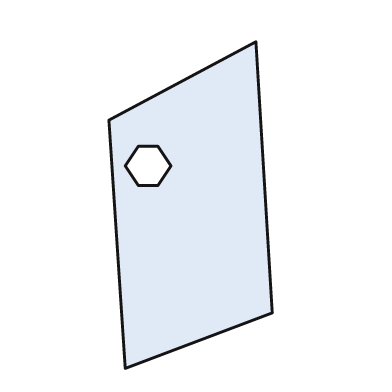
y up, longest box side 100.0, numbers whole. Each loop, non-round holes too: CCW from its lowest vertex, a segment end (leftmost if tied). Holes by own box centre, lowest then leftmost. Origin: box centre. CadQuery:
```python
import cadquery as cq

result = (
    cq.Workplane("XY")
    .moveTo(-20.0, -50.0)
    .lineTo(25.0, -33.0)
    .lineTo(20.0, 50.0)
    .lineTo(-25.0, 26.0)
    .close()
    .moveTo(-16.0, 6.0)
    .lineTo(-10.0, 6.0)
    .lineTo(-6.0, 12.0)
    .lineTo(-10.0, 18.0)
    .lineTo(-16.0, 18.0)
    .lineTo(-20.0, 12.0)
    .close()
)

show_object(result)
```